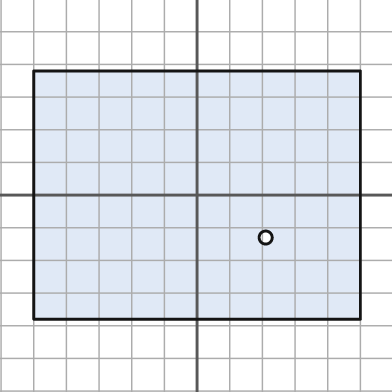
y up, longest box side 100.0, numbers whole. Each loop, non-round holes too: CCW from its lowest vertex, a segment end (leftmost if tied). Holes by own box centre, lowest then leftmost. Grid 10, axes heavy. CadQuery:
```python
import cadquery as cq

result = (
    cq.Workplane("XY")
    .moveTo(-50.0, -38.0)
    .lineTo(50.0, -38.0)
    .lineTo(50.0, 38.0)
    .lineTo(-50.0, 38.0)
    .close()
    .moveTo(21.0, -13.0)
    .circle(2.0)
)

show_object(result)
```